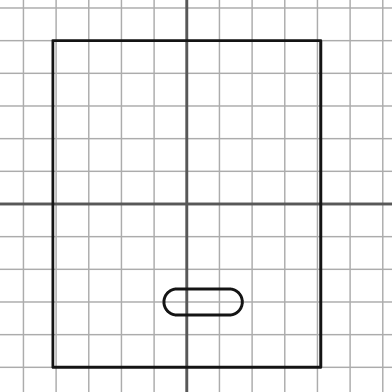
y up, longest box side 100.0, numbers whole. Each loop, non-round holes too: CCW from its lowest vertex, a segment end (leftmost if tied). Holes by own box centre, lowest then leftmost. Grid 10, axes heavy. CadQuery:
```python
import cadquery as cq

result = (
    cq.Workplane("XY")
    .moveTo(-41.0, -50.0)
    .lineTo(41.0, -50.0)
    .lineTo(41.0, 50.0)
    .lineTo(-41.0, 50.0)
    .close()
    .moveTo(-3.0, -34.0)
    .lineTo(13.0, -34.0)
    .threePointArc((17.0, -30.0), (13.0, -26.0))
    .lineTo(-3.0, -26.0)
    .threePointArc((-7.0, -30.0), (-3.0, -34.0))
    .close()
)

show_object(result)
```